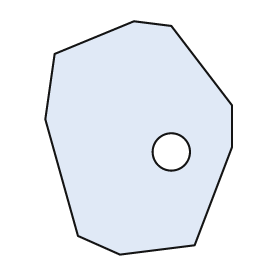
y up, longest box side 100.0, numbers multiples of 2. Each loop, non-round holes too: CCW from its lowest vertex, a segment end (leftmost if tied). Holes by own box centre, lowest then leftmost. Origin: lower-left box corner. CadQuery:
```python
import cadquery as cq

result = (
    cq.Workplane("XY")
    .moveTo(32.0, 0.0)
    .lineTo(64.0, 4.0)
    .lineTo(80.0, 46.0)
    .lineTo(80.0, 64.0)
    .lineTo(54.0, 98.0)
    .lineTo(38.0, 100.0)
    .lineTo(4.0, 86.0)
    .lineTo(0.0, 58.0)
    .lineTo(14.0, 8.0)
    .close()
    .moveTo(54.0, 44.0)
    .circle(8.0)
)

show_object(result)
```